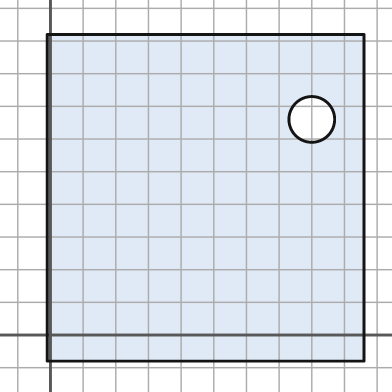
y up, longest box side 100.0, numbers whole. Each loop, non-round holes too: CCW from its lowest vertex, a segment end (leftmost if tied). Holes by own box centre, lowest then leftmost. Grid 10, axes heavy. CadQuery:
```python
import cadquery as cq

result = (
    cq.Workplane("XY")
    .moveTo(-1.0, -8.0)
    .lineTo(96.0, -8.0)
    .lineTo(96.0, 92.0)
    .lineTo(-1.0, 92.0)
    .close()
    .moveTo(80.0, 66.0)
    .circle(7.0)
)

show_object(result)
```